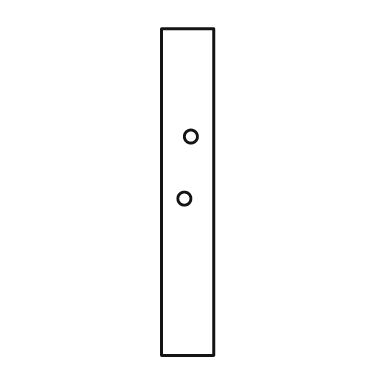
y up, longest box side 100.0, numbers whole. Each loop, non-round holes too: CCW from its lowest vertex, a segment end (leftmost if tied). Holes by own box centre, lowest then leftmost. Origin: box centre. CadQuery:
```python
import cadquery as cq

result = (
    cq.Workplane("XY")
    .moveTo(-8.0, -50.0)
    .lineTo(8.0, -50.0)
    .lineTo(8.0, 50.0)
    .lineTo(-8.0, 50.0)
    .close()
    .moveTo(-1.0, -2.0)
    .circle(2.0)
    .moveTo(1.0, 17.0)
    .circle(2.0)
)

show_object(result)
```